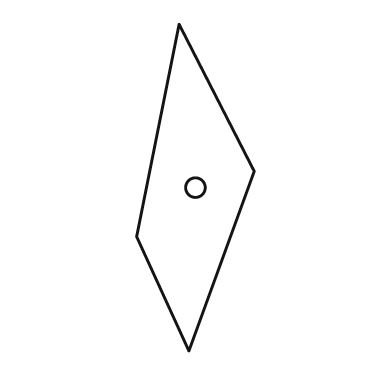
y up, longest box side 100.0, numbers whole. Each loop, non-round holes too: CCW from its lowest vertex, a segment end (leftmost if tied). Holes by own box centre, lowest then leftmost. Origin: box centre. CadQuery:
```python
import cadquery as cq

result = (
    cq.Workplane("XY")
    .moveTo(-2.0, -50.0)
    .lineTo(18.0, 5.0)
    .lineTo(-5.0, 50.0)
    .lineTo(-18.0, -15.0)
    .close()
    .moveTo(0.0, 0.0)
    .circle(3.0)
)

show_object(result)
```